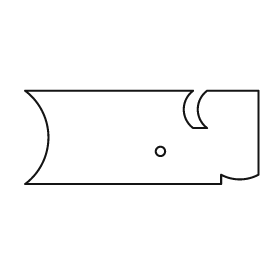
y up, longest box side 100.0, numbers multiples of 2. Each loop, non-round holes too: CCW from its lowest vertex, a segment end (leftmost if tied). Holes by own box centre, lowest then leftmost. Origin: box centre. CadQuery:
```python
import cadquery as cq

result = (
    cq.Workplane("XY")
    .moveTo(-50.0, -20.0)
    .lineTo(34.0, -20.0)
    .lineTo(34.0, -16.0)
    .threePointArc((42.0, -18.0), (50.0, -16.0))
    .lineTo(50.0, 20.0)
    .lineTo(28.0, 20.0)
    .threePointArc((24.0, 12.0), (28.0, 4.0))
    .lineTo(22.0, 4.0)
    .threePointArc((18.0, 12.0), (22.0, 20.0))
    .lineTo(-50.0, 20.0)
    .threePointArc((-40.0, 0.0), (-50.0, -20.0))
    .close()
    .moveTo(8.0, -6.0)
    .circle(2.0)
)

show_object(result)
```